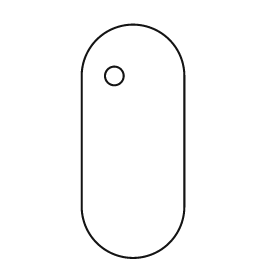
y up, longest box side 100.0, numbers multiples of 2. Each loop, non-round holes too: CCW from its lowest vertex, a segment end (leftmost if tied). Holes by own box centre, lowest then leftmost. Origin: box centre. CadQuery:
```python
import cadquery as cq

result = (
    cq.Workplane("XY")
    .moveTo(-22.0, -28.0)
    .threePointArc((0.0, -50.0), (22.0, -28.0))
    .lineTo(22.0, 28.0)
    .threePointArc((0.0, 50.0), (-22.0, 28.0))
    .close()
    .moveTo(-8.0, 28.0)
    .circle(4.0)
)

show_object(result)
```